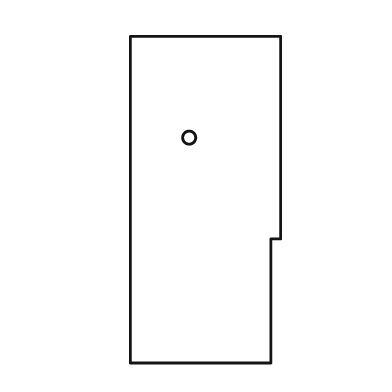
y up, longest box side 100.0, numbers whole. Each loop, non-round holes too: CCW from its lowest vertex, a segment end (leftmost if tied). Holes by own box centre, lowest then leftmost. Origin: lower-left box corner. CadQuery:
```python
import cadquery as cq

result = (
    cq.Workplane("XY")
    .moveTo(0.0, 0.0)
    .lineTo(43.0, 0.0)
    .lineTo(43.0, 38.0)
    .lineTo(46.0, 38.0)
    .lineTo(46.0, 100.0)
    .lineTo(0.0, 100.0)
    .close()
    .moveTo(18.0, 69.0)
    .circle(2.0)
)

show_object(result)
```